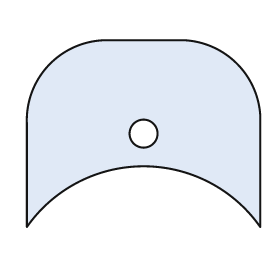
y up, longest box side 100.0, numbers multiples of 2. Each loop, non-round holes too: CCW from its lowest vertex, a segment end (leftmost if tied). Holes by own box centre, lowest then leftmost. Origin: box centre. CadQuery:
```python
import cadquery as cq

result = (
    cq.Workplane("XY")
    .moveTo(-50.0, -40.0)
    .threePointArc((0.0, -14.0), (50.0, -40.0))
    .lineTo(50.0, 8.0)
    .threePointArc((40.0, 30.0), (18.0, 40.0))
    .lineTo(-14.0, 40.0)
    .threePointArc((-40.0, 30.0), (-50.0, 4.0))
    .close()
    .moveTo(0.0, 0.0)
    .circle(6.0)
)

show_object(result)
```